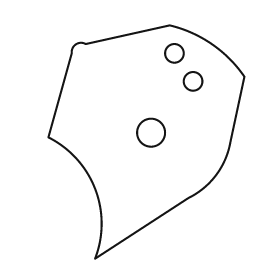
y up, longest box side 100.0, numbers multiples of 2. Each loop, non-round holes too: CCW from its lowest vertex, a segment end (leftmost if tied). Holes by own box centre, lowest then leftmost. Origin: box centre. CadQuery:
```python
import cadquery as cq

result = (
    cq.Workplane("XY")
    .moveTo(-22.0, -50.0)
    .lineTo(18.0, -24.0)
    .threePointArc((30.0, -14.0), (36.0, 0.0))
    .lineTo(42.0, 28.0)
    .threePointArc((28.0, 42.0), (10.0, 50.0))
    .lineTo(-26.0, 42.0)
    .threePointArc((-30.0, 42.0), (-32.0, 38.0))
    .lineTo(-42.0, 2.0)
    .threePointArc((-22.0, -20.0), (-22.0, -50.0))
    .close()
    .moveTo(2.0, 4.0)
    .circle(6.0)
    .moveTo(20.0, 26.0)
    .circle(4.0)
    .moveTo(12.0, 38.0)
    .circle(4.0)
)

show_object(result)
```